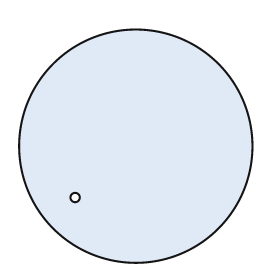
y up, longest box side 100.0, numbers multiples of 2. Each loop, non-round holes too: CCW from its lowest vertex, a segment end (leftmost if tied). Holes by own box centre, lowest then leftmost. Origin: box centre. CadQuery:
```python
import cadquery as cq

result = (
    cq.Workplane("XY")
    .moveTo(0.0, 0.0)
    .circle(50.0)
    .moveTo(-26.0, -22.0)
    .circle(2.0)
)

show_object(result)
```